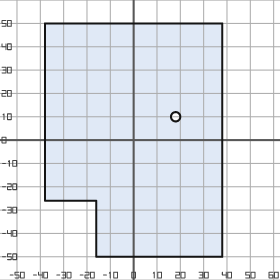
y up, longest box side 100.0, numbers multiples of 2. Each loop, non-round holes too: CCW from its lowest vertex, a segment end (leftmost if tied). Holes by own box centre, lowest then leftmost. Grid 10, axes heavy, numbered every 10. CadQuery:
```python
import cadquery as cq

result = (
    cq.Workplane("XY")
    .moveTo(-16.0, -50.0)
    .lineTo(38.0, -50.0)
    .lineTo(38.0, 50.0)
    .lineTo(-38.0, 50.0)
    .lineTo(-38.0, -26.0)
    .lineTo(-16.0, -26.0)
    .close()
    .moveTo(18.0, 10.0)
    .circle(2.0)
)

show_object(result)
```